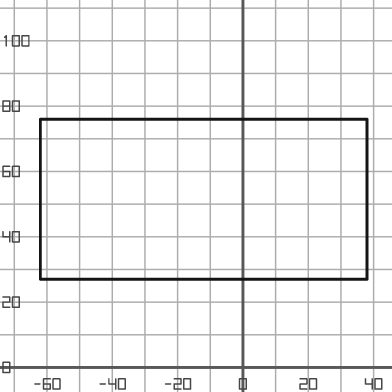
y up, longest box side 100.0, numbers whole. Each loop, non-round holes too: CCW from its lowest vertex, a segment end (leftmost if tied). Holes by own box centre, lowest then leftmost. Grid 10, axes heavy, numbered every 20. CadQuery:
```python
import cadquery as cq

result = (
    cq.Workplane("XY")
    .moveTo(-62.0, 27.0)
    .lineTo(38.0, 27.0)
    .lineTo(38.0, 76.0)
    .lineTo(-62.0, 76.0)
    .close()
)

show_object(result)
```